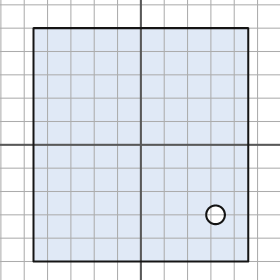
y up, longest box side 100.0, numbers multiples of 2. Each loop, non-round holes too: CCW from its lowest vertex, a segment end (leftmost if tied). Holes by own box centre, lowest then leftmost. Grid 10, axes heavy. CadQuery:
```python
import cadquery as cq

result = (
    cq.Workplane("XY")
    .moveTo(-46.0, -50.0)
    .lineTo(46.0, -50.0)
    .lineTo(46.0, 50.0)
    .lineTo(-46.0, 50.0)
    .close()
    .moveTo(32.0, -30.0)
    .circle(4.0)
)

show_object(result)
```